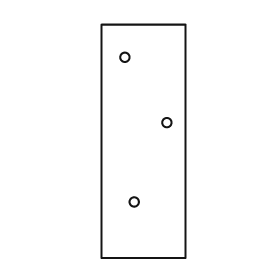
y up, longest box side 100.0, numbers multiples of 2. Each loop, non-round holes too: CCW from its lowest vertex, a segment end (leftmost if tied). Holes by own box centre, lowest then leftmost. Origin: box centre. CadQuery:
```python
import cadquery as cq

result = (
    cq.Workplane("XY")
    .moveTo(-18.0, -50.0)
    .lineTo(18.0, -50.0)
    .lineTo(18.0, 50.0)
    .lineTo(-18.0, 50.0)
    .close()
    .moveTo(-4.0, -26.0)
    .circle(2.0)
    .moveTo(10.0, 8.0)
    .circle(2.0)
    .moveTo(-8.0, 36.0)
    .circle(2.0)
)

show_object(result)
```